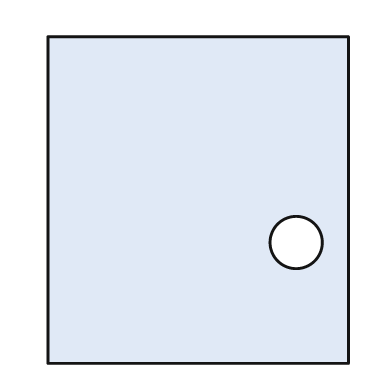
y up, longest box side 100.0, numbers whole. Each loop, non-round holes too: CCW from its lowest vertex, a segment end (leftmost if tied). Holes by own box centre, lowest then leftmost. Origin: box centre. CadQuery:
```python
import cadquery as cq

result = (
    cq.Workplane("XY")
    .moveTo(-46.0, -50.0)
    .lineTo(46.0, -50.0)
    .lineTo(46.0, 50.0)
    .lineTo(-46.0, 50.0)
    .close()
    .moveTo(30.0, -13.0)
    .circle(8.0)
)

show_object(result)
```